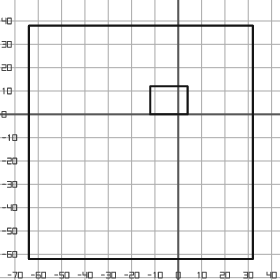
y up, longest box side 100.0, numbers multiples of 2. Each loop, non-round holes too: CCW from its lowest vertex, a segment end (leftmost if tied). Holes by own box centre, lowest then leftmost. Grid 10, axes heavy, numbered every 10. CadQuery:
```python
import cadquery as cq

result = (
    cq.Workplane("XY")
    .moveTo(-64.0, -62.0)
    .lineTo(32.0, -62.0)
    .lineTo(32.0, 38.0)
    .lineTo(-64.0, 38.0)
    .close()
    .moveTo(-12.0, 0.0)
    .lineTo(4.0, 0.0)
    .lineTo(4.0, 12.0)
    .lineTo(-12.0, 12.0)
    .close()
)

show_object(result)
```